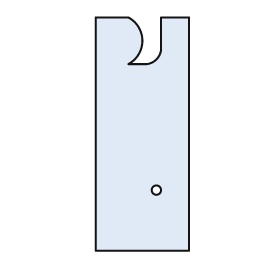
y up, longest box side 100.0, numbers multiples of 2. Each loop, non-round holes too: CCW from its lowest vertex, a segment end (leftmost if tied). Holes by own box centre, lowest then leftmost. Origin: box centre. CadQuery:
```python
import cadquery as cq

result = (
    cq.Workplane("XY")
    .moveTo(-20.0, -50.0)
    .lineTo(20.0, -50.0)
    .lineTo(20.0, 50.0)
    .lineTo(8.0, 50.0)
    .lineTo(8.0, 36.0)
    .threePointArc((6.0, 32.0), (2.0, 30.0))
    .lineTo(-6.0, 30.0)
    .threePointArc((0.0, 40.0), (-6.0, 50.0))
    .lineTo(-20.0, 50.0)
    .close()
    .moveTo(6.0, -24.0)
    .circle(2.0)
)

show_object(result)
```